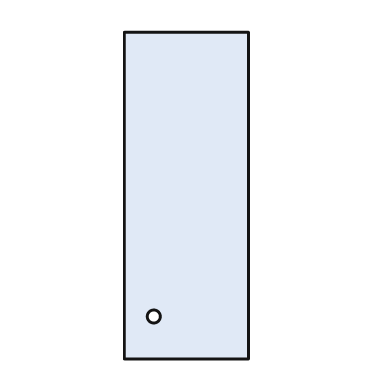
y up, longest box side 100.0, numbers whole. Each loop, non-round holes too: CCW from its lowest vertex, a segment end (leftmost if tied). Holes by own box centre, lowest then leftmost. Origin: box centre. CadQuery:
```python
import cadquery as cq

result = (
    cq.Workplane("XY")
    .moveTo(-19.0, -50.0)
    .lineTo(19.0, -50.0)
    .lineTo(19.0, 50.0)
    .lineTo(-19.0, 50.0)
    .close()
    .moveTo(-10.0, -37.0)
    .circle(2.0)
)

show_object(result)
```